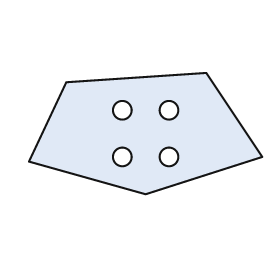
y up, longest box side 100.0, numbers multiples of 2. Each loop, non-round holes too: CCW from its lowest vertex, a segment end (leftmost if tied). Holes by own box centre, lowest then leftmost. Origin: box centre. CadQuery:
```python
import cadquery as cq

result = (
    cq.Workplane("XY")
    .moveTo(0.0, -26.0)
    .lineTo(50.0, -10.0)
    .lineTo(26.0, 26.0)
    .lineTo(-34.0, 22.0)
    .lineTo(-50.0, -12.0)
    .close()
    .moveTo(-10.0, -10.0)
    .circle(4.0)
    .moveTo(10.0, -10.0)
    .circle(4.0)
    .moveTo(-10.0, 10.0)
    .circle(4.0)
    .moveTo(10.0, 10.0)
    .circle(4.0)
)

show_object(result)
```